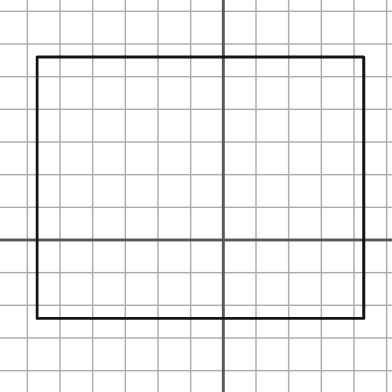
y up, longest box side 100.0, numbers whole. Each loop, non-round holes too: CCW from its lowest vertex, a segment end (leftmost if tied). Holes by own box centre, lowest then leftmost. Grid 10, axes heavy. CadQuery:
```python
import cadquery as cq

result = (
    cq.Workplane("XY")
    .moveTo(-57.0, -24.0)
    .lineTo(43.0, -24.0)
    .lineTo(43.0, 56.0)
    .lineTo(-57.0, 56.0)
    .close()
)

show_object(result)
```